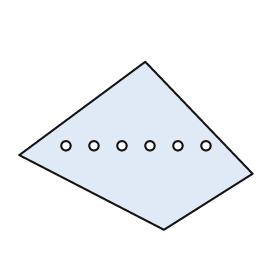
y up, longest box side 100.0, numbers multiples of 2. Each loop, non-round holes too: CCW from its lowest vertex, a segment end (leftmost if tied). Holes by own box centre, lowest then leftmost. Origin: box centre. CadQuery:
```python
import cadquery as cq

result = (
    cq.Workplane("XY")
    .moveTo(12.0, -36.0)
    .lineTo(50.0, -12.0)
    .lineTo(4.0, 36.0)
    .lineTo(-50.0, -4.0)
    .close()
    .moveTo(-30.0, 0.0)
    .circle(2.0)
    .moveTo(-18.0, 0.0)
    .circle(2.0)
    .moveTo(-6.0, 0.0)
    .circle(2.0)
    .moveTo(6.0, 0.0)
    .circle(2.0)
    .moveTo(18.0, 0.0)
    .circle(2.0)
    .moveTo(30.0, 0.0)
    .circle(2.0)
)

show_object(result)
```